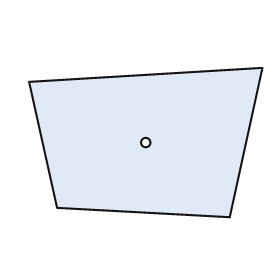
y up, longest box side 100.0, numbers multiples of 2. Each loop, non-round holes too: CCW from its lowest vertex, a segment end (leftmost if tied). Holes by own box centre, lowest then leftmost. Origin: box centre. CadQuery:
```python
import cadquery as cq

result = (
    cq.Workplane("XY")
    .moveTo(36.0, -32.0)
    .lineTo(50.0, 32.0)
    .lineTo(-50.0, 26.0)
    .lineTo(-38.0, -28.0)
    .close()
    .moveTo(0.0, 0.0)
    .circle(2.0)
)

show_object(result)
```